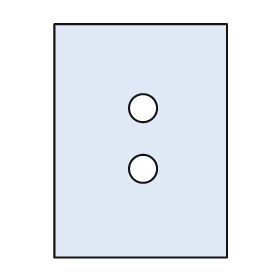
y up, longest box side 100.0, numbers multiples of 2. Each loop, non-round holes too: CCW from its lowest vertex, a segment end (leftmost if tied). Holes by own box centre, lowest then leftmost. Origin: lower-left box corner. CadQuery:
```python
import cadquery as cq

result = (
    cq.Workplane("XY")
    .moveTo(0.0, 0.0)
    .lineTo(74.0, 0.0)
    .lineTo(74.0, 100.0)
    .lineTo(0.0, 100.0)
    .close()
    .moveTo(38.0, 38.0)
    .circle(6.0)
    .moveTo(38.0, 64.0)
    .circle(6.0)
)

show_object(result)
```